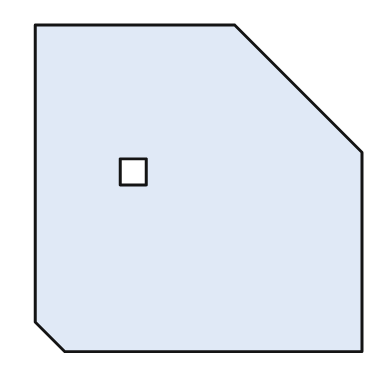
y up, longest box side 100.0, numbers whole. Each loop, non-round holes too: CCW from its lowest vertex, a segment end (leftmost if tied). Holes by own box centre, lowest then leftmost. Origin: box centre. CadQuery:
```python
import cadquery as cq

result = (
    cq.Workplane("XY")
    .moveTo(-41.0, -50.0)
    .lineTo(50.0, -50.0)
    .lineTo(50.0, 11.0)
    .lineTo(11.0, 50.0)
    .lineTo(-50.0, 50.0)
    .lineTo(-50.0, -41.0)
    .close()
    .moveTo(-24.0, 1.0)
    .lineTo(-16.0, 1.0)
    .lineTo(-16.0, 9.0)
    .lineTo(-24.0, 9.0)
    .close()
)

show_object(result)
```